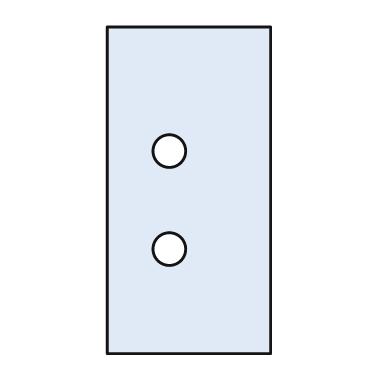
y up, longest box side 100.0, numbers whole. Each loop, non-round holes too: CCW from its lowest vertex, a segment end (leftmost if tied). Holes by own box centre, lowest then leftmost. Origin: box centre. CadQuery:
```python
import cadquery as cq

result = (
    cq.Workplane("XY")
    .moveTo(-25.0, -50.0)
    .lineTo(25.0, -50.0)
    .lineTo(25.0, 50.0)
    .lineTo(-25.0, 50.0)
    .close()
    .moveTo(-6.0, -18.0)
    .circle(5.0)
    .moveTo(-6.0, 12.0)
    .circle(5.0)
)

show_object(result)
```